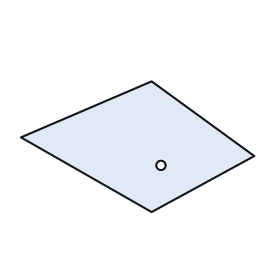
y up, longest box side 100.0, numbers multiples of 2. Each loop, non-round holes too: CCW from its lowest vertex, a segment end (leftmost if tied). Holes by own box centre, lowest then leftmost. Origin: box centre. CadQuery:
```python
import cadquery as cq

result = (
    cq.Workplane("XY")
    .moveTo(6.0, -28.0)
    .lineTo(50.0, -4.0)
    .lineTo(6.0, 28.0)
    .lineTo(-50.0, 4.0)
    .close()
    .moveTo(10.0, -8.0)
    .circle(2.0)
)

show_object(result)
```